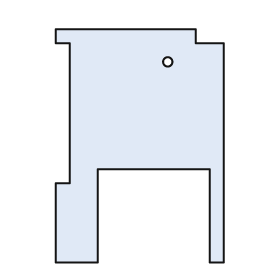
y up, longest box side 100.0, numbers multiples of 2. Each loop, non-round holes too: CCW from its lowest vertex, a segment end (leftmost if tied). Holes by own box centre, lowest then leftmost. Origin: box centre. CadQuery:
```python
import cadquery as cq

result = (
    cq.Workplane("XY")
    .moveTo(-36.0, -50.0)
    .lineTo(-18.0, -50.0)
    .lineTo(-18.0, -10.0)
    .lineTo(30.0, -10.0)
    .lineTo(30.0, -50.0)
    .lineTo(36.0, -50.0)
    .lineTo(36.0, 44.0)
    .lineTo(24.0, 44.0)
    .lineTo(24.0, 50.0)
    .lineTo(-36.0, 50.0)
    .lineTo(-36.0, 44.0)
    .lineTo(-30.0, 44.0)
    .lineTo(-30.0, -16.0)
    .lineTo(-36.0, -16.0)
    .close()
    .moveTo(12.0, 36.0)
    .circle(2.0)
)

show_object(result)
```